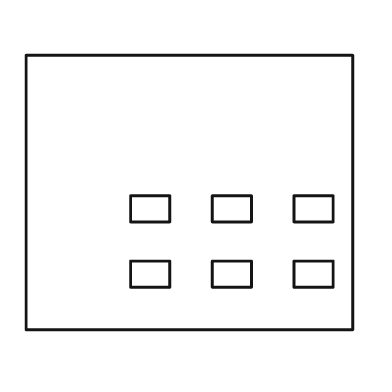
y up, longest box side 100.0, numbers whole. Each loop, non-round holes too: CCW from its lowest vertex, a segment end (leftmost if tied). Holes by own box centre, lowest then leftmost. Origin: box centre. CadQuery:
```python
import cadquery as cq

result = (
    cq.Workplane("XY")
    .moveTo(-50.0, -42.0)
    .lineTo(50.0, -42.0)
    .lineTo(50.0, 42.0)
    .lineTo(-50.0, 42.0)
    .close()
    .moveTo(-18.0, -29.0)
    .lineTo(-6.0, -29.0)
    .lineTo(-6.0, -21.0)
    .lineTo(-18.0, -21.0)
    .close()
    .moveTo(7.0, -29.0)
    .lineTo(19.0, -29.0)
    .lineTo(19.0, -21.0)
    .lineTo(7.0, -21.0)
    .close()
    .moveTo(32.0, -29.0)
    .lineTo(44.0, -29.0)
    .lineTo(44.0, -21.0)
    .lineTo(32.0, -21.0)
    .close()
    .moveTo(-18.0, -9.0)
    .lineTo(-6.0, -9.0)
    .lineTo(-6.0, -1.0)
    .lineTo(-18.0, -1.0)
    .close()
    .moveTo(7.0, -9.0)
    .lineTo(19.0, -9.0)
    .lineTo(19.0, -1.0)
    .lineTo(7.0, -1.0)
    .close()
    .moveTo(32.0, -9.0)
    .lineTo(44.0, -9.0)
    .lineTo(44.0, -1.0)
    .lineTo(32.0, -1.0)
    .close()
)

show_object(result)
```